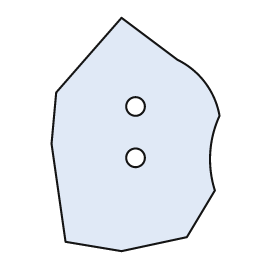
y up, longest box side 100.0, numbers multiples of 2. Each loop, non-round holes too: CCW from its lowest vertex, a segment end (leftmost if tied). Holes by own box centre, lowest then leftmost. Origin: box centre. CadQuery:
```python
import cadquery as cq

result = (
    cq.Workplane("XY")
    .moveTo(-6.0, -50.0)
    .lineTo(22.0, -44.0)
    .lineTo(34.0, -24.0)
    .threePointArc((32.0, -8.0), (36.0, 8.0))
    .threePointArc((30.0, 22.0), (18.0, 32.0))
    .lineTo(-6.0, 50.0)
    .lineTo(-34.0, 18.0)
    .lineTo(-36.0, -4.0)
    .lineTo(-30.0, -46.0)
    .close()
    .moveTo(0.0, -10.0)
    .circle(4.0)
    .moveTo(0.0, 12.0)
    .circle(4.0)
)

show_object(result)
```